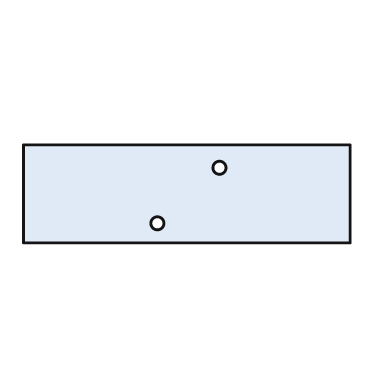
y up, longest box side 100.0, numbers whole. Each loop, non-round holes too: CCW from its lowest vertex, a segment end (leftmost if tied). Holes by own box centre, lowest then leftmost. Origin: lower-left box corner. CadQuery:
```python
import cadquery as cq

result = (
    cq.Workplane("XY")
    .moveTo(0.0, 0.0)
    .lineTo(100.0, 0.0)
    .lineTo(100.0, 30.0)
    .lineTo(0.0, 30.0)
    .close()
    .moveTo(41.0, 6.0)
    .circle(2.0)
    .moveTo(60.0, 23.0)
    .circle(2.0)
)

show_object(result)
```